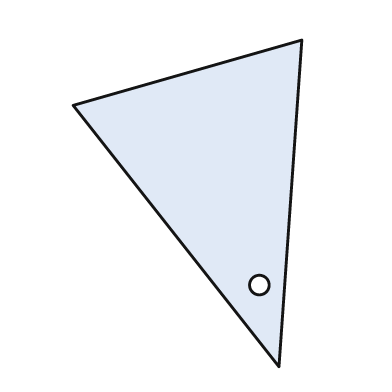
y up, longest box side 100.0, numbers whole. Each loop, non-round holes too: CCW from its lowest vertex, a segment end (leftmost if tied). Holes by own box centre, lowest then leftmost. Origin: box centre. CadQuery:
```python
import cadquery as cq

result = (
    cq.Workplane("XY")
    .moveTo(28.0, -50.0)
    .lineTo(35.0, 50.0)
    .lineTo(-35.0, 30.0)
    .close()
    .moveTo(22.0, -25.0)
    .circle(3.0)
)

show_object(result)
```